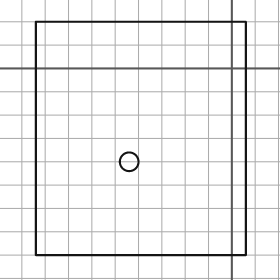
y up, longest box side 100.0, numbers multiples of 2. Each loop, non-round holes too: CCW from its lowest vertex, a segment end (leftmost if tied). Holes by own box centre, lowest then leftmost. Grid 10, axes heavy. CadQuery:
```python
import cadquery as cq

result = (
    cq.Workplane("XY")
    .moveTo(-84.0, -80.0)
    .lineTo(6.0, -80.0)
    .lineTo(6.0, 20.0)
    .lineTo(-84.0, 20.0)
    .close()
    .moveTo(-44.0, -40.0)
    .circle(4.0)
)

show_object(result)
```